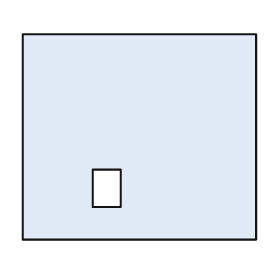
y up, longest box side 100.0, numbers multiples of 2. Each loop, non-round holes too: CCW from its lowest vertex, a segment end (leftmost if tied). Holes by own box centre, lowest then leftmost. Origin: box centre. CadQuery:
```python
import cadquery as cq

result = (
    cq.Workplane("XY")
    .moveTo(-50.0, -44.0)
    .lineTo(50.0, -44.0)
    .lineTo(50.0, 44.0)
    .lineTo(-50.0, 44.0)
    .close()
    .moveTo(-20.0, -30.0)
    .lineTo(-8.0, -30.0)
    .lineTo(-8.0, -14.0)
    .lineTo(-20.0, -14.0)
    .close()
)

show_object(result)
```